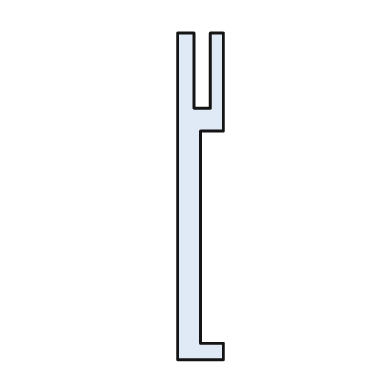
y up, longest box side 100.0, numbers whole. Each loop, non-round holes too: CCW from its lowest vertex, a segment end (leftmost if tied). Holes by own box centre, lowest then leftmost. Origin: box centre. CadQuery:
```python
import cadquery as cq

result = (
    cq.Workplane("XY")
    .moveTo(-7.0, -50.0)
    .lineTo(7.0, -50.0)
    .lineTo(7.0, -45.0)
    .lineTo(0.0, -45.0)
    .lineTo(0.0, 20.0)
    .lineTo(7.0, 20.0)
    .lineTo(7.0, 50.0)
    .lineTo(3.0, 50.0)
    .lineTo(3.0, 27.0)
    .lineTo(-2.0, 27.0)
    .lineTo(-2.0, 50.0)
    .lineTo(-7.0, 50.0)
    .close()
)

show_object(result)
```